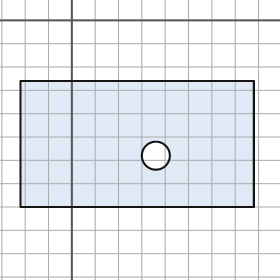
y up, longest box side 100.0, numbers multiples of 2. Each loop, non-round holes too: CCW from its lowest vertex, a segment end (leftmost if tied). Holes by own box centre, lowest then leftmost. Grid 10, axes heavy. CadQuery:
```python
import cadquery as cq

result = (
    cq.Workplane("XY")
    .moveTo(-22.0, -80.0)
    .lineTo(78.0, -80.0)
    .lineTo(78.0, -26.0)
    .lineTo(-22.0, -26.0)
    .close()
    .moveTo(36.0, -58.0)
    .circle(6.0)
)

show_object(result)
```